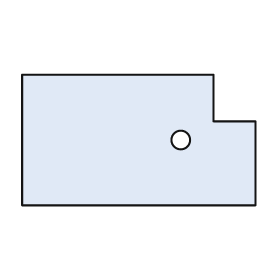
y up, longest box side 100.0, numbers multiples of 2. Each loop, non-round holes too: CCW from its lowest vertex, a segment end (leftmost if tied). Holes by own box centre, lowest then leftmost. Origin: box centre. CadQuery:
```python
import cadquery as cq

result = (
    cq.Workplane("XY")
    .moveTo(-50.0, -28.0)
    .lineTo(50.0, -28.0)
    .lineTo(50.0, 8.0)
    .lineTo(32.0, 8.0)
    .lineTo(32.0, 28.0)
    .lineTo(-50.0, 28.0)
    .close()
    .moveTo(18.0, 0.0)
    .circle(4.0)
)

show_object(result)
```